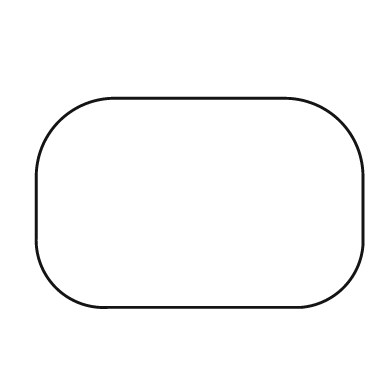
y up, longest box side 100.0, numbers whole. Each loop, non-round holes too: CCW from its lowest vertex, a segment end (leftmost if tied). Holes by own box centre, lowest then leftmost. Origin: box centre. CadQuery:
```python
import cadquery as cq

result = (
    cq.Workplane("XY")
    .moveTo(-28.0, -32.0)
    .lineTo(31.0, -32.0)
    .threePointArc((44.0, -26.0), (50.0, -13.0))
    .lineTo(50.0, 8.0)
    .threePointArc((43.0, 25.0), (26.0, 32.0))
    .lineTo(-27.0, 32.0)
    .threePointArc((-43.0, 25.0), (-50.0, 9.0))
    .lineTo(-50.0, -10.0)
    .threePointArc((-44.0, -26.0), (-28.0, -32.0))
    .close()
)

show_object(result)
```